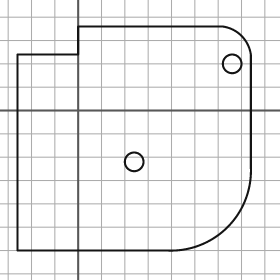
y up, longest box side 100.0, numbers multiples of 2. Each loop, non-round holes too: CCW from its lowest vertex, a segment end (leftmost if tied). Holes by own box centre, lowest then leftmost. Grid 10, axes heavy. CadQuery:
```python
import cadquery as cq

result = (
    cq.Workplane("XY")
    .moveTo(-26.0, -60.0)
    .lineTo(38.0, -60.0)
    .threePointArc((64.0, -50.0), (74.0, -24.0))
    .lineTo(74.0, 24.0)
    .threePointArc((70.0, 32.0), (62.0, 36.0))
    .lineTo(0.0, 36.0)
    .lineTo(0.0, 24.0)
    .lineTo(-26.0, 24.0)
    .close()
    .moveTo(24.0, -22.0)
    .circle(4.0)
    .moveTo(66.0, 20.0)
    .circle(4.0)
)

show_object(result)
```